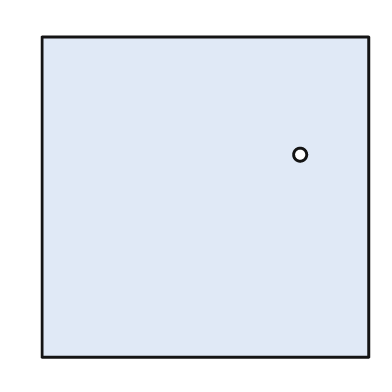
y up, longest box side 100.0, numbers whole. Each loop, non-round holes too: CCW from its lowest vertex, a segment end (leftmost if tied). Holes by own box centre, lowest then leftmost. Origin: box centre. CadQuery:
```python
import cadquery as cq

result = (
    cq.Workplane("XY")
    .moveTo(-50.0, -49.0)
    .lineTo(50.0, -49.0)
    .lineTo(50.0, 49.0)
    .lineTo(-50.0, 49.0)
    .close()
    .moveTo(29.0, 13.0)
    .circle(2.0)
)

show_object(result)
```